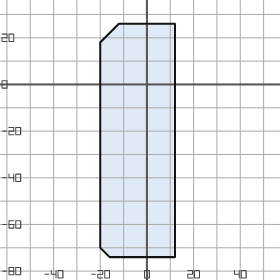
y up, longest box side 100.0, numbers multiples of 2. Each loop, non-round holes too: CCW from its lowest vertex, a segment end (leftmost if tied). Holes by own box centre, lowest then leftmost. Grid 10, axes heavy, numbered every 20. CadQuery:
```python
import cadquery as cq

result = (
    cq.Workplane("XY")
    .moveTo(-16.0, -74.0)
    .lineTo(12.0, -74.0)
    .lineTo(12.0, 26.0)
    .lineTo(-12.0, 26.0)
    .lineTo(-20.0, 18.0)
    .lineTo(-20.0, -70.0)
    .close()
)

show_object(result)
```